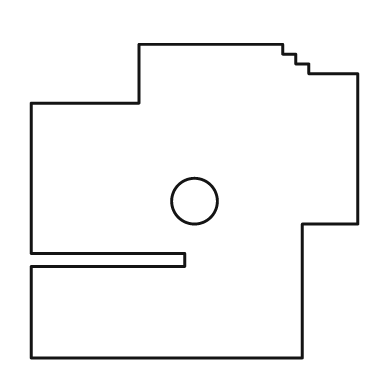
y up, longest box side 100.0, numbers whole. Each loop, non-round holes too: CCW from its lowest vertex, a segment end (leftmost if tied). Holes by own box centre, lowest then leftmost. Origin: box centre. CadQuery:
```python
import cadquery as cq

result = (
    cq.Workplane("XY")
    .moveTo(-50.0, -48.0)
    .lineTo(33.0, -48.0)
    .lineTo(33.0, -7.0)
    .lineTo(50.0, -7.0)
    .lineTo(50.0, 39.0)
    .lineTo(35.0, 39.0)
    .lineTo(35.0, 42.0)
    .lineTo(31.0, 42.0)
    .lineTo(31.0, 45.0)
    .lineTo(27.0, 45.0)
    .lineTo(27.0, 48.0)
    .lineTo(-17.0, 48.0)
    .lineTo(-17.0, 30.0)
    .lineTo(-50.0, 30.0)
    .lineTo(-50.0, -16.0)
    .lineTo(-3.0, -16.0)
    .lineTo(-3.0, -20.0)
    .lineTo(-50.0, -20.0)
    .close()
    .moveTo(0.0, 0.0)
    .circle(7.0)
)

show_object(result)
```